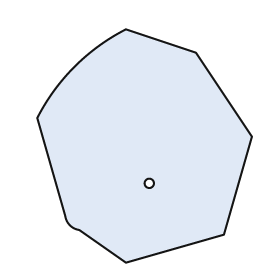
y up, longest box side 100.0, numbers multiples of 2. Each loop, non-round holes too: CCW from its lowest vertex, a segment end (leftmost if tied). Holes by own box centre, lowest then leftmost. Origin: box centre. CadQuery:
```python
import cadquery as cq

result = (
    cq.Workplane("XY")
    .moveTo(-8.0, -50.0)
    .lineTo(34.0, -38.0)
    .lineTo(46.0, 4.0)
    .lineTo(22.0, 40.0)
    .lineTo(-8.0, 50.0)
    .threePointArc((-30.0, 34.0), (-46.0, 12.0))
    .lineTo(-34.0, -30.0)
    .threePointArc((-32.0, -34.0), (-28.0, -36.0))
    .close()
    .moveTo(2.0, -16.0)
    .circle(2.0)
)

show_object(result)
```